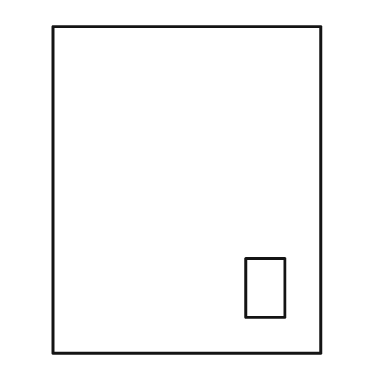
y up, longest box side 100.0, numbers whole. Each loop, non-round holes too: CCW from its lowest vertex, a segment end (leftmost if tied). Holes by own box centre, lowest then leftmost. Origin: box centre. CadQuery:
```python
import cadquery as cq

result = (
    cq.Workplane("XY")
    .moveTo(-41.0, -50.0)
    .lineTo(41.0, -50.0)
    .lineTo(41.0, 50.0)
    .lineTo(-41.0, 50.0)
    .close()
    .moveTo(18.0, -39.0)
    .lineTo(30.0, -39.0)
    .lineTo(30.0, -21.0)
    .lineTo(18.0, -21.0)
    .close()
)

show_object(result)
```